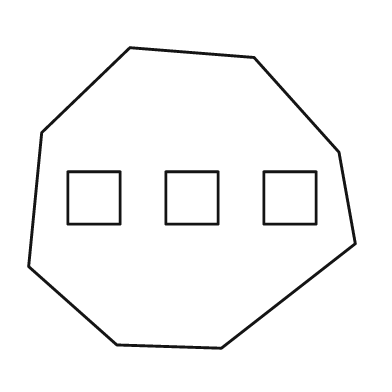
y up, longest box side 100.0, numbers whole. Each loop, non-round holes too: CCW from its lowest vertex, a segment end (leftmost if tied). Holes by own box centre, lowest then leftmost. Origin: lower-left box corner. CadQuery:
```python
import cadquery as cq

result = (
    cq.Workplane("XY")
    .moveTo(59.0, 0.0)
    .lineTo(100.0, 32.0)
    .lineTo(95.0, 60.0)
    .lineTo(69.0, 89.0)
    .lineTo(31.0, 92.0)
    .lineTo(4.0, 66.0)
    .lineTo(0.0, 25.0)
    .lineTo(27.0, 1.0)
    .close()
    .moveTo(12.0, 38.0)
    .lineTo(28.0, 38.0)
    .lineTo(28.0, 54.0)
    .lineTo(12.0, 54.0)
    .close()
    .moveTo(42.0, 38.0)
    .lineTo(58.0, 38.0)
    .lineTo(58.0, 54.0)
    .lineTo(42.0, 54.0)
    .close()
    .moveTo(72.0, 38.0)
    .lineTo(88.0, 38.0)
    .lineTo(88.0, 54.0)
    .lineTo(72.0, 54.0)
    .close()
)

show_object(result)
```